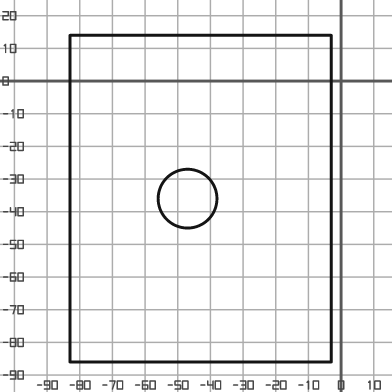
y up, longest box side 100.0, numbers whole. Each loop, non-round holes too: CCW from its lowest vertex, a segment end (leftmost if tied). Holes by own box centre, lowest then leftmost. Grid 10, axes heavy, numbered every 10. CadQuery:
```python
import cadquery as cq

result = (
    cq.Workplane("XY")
    .moveTo(-83.0, -86.0)
    .lineTo(-3.0, -86.0)
    .lineTo(-3.0, 14.0)
    .lineTo(-83.0, 14.0)
    .close()
    .moveTo(-47.0, -36.0)
    .circle(9.0)
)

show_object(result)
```